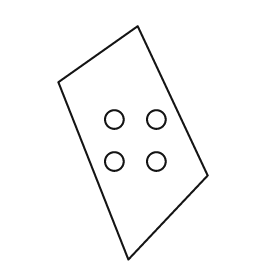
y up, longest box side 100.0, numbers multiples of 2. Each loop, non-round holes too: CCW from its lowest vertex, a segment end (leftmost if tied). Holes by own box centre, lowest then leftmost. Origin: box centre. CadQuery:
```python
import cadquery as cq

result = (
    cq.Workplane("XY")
    .moveTo(-2.0, -50.0)
    .lineTo(32.0, -14.0)
    .lineTo(2.0, 50.0)
    .lineTo(-32.0, 26.0)
    .close()
    .moveTo(-8.0, -8.0)
    .circle(4.0)
    .moveTo(10.0, -8.0)
    .circle(4.0)
    .moveTo(-8.0, 10.0)
    .circle(4.0)
    .moveTo(10.0, 10.0)
    .circle(4.0)
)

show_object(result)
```